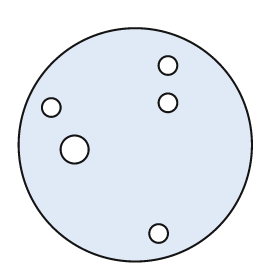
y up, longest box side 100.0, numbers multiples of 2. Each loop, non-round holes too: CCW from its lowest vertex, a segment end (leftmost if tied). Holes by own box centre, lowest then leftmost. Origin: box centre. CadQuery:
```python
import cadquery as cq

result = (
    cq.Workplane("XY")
    .moveTo(0.0, 0.0)
    .circle(50.0)
    .moveTo(10.0, -38.0)
    .circle(4.0)
    .moveTo(-26.0, -2.0)
    .circle(6.0)
    .moveTo(-36.0, 16.0)
    .circle(4.0)
    .moveTo(14.0, 18.0)
    .circle(4.0)
    .moveTo(14.0, 34.0)
    .circle(4.0)
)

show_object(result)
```